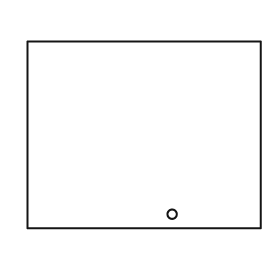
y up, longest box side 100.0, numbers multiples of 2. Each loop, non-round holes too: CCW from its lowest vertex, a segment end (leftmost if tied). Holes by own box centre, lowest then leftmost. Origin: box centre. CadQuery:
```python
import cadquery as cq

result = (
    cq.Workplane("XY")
    .moveTo(-50.0, -40.0)
    .lineTo(50.0, -40.0)
    .lineTo(50.0, 40.0)
    .lineTo(-50.0, 40.0)
    .close()
    .moveTo(12.0, -34.0)
    .circle(2.0)
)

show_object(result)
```